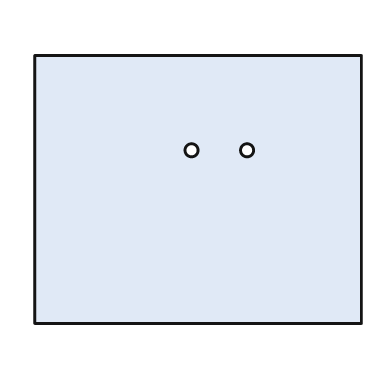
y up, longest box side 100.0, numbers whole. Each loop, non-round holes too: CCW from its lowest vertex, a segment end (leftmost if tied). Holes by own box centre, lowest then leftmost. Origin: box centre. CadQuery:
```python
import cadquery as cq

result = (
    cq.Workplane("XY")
    .moveTo(-50.0, -41.0)
    .lineTo(50.0, -41.0)
    .lineTo(50.0, 41.0)
    .lineTo(-50.0, 41.0)
    .close()
    .moveTo(-2.0, 12.0)
    .circle(2.0)
    .moveTo(15.0, 12.0)
    .circle(2.0)
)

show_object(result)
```